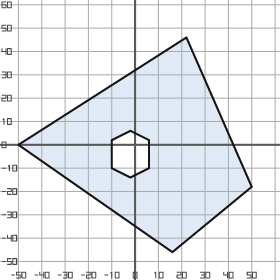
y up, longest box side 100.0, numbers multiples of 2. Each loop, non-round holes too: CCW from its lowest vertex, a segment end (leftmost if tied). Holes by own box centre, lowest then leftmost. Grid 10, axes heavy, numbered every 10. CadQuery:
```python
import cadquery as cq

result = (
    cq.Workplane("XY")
    .moveTo(16.0, -46.0)
    .lineTo(50.0, -18.0)
    .lineTo(22.0, 46.0)
    .lineTo(-50.0, 0.0)
    .close()
    .moveTo(-2.0, -14.0)
    .lineTo(6.0, -10.0)
    .lineTo(6.0, 2.0)
    .lineTo(-2.0, 6.0)
    .lineTo(-10.0, 2.0)
    .lineTo(-10.0, -10.0)
    .close()
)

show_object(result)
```